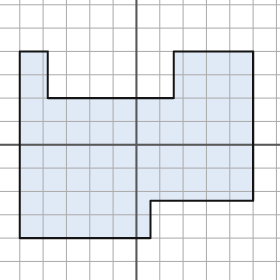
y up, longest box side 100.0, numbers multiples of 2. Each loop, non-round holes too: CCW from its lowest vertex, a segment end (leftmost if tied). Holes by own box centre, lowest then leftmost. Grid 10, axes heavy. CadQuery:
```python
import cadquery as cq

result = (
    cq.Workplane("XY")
    .moveTo(-50.0, -40.0)
    .lineTo(6.0, -40.0)
    .lineTo(6.0, -24.0)
    .lineTo(50.0, -24.0)
    .lineTo(50.0, 40.0)
    .lineTo(16.0, 40.0)
    .lineTo(16.0, 20.0)
    .lineTo(-38.0, 20.0)
    .lineTo(-38.0, 40.0)
    .lineTo(-50.0, 40.0)
    .close()
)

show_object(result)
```